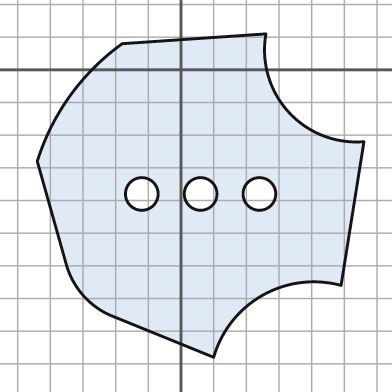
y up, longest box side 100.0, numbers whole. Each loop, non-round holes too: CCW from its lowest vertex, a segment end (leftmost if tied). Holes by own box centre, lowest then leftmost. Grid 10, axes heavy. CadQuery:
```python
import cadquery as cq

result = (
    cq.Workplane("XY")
    .moveTo(10.0, -88.0)
    .threePointArc((25.0, -69.0), (49.0, -66.0))
    .lineTo(56.0, -22.0)
    .threePointArc((33.0, -13.0), (26.0, 11.0))
    .lineTo(-18.0, 8.0)
    .threePointArc((-34.0, -8.0), (-44.0, -28.0))
    .lineTo(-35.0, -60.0)
    .threePointArc((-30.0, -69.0), (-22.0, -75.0))
    .close()
    .moveTo(-12.0, -38.0)
    .circle(5.0)
    .moveTo(6.0, -38.0)
    .circle(5.0)
    .moveTo(24.0, -38.0)
    .circle(5.0)
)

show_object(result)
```